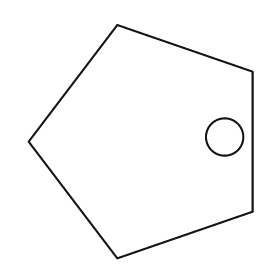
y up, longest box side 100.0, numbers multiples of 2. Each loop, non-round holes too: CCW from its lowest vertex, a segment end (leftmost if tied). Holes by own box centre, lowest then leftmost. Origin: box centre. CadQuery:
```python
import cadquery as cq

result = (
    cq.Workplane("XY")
    .moveTo(-10.0, -50.0)
    .lineTo(48.0, -30.0)
    .lineTo(48.0, 30.0)
    .lineTo(-10.0, 50.0)
    .lineTo(-48.0, 0.0)
    .close()
    .moveTo(36.0, 2.0)
    .circle(8.0)
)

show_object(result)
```